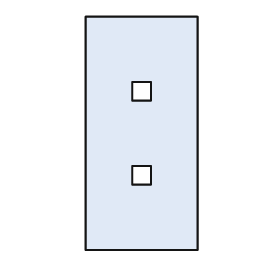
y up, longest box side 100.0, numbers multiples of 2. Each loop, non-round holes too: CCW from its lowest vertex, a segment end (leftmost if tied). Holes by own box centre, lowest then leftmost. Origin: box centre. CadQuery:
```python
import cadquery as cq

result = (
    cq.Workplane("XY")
    .moveTo(-24.0, -50.0)
    .lineTo(24.0, -50.0)
    .lineTo(24.0, 50.0)
    .lineTo(-24.0, 50.0)
    .close()
    .moveTo(-4.0, -22.0)
    .lineTo(4.0, -22.0)
    .lineTo(4.0, -14.0)
    .lineTo(-4.0, -14.0)
    .close()
    .moveTo(-4.0, 14.0)
    .lineTo(4.0, 14.0)
    .lineTo(4.0, 22.0)
    .lineTo(-4.0, 22.0)
    .close()
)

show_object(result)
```